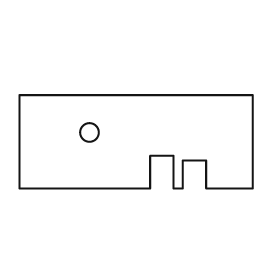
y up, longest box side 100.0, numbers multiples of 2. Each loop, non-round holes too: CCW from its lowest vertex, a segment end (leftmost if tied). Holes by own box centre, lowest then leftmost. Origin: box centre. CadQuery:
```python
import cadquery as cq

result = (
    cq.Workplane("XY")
    .moveTo(-50.0, -20.0)
    .lineTo(6.0, -20.0)
    .lineTo(6.0, -6.0)
    .lineTo(16.0, -6.0)
    .lineTo(16.0, -20.0)
    .lineTo(20.0, -20.0)
    .lineTo(20.0, -8.0)
    .lineTo(30.0, -8.0)
    .lineTo(30.0, -20.0)
    .lineTo(50.0, -20.0)
    .lineTo(50.0, 20.0)
    .lineTo(-50.0, 20.0)
    .close()
    .moveTo(-20.0, 4.0)
    .circle(4.0)
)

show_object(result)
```